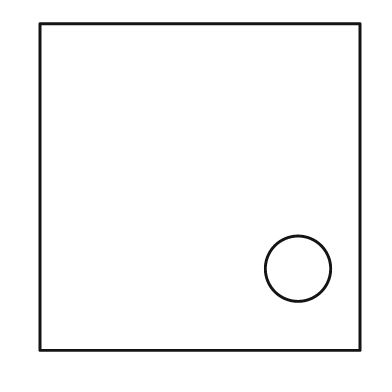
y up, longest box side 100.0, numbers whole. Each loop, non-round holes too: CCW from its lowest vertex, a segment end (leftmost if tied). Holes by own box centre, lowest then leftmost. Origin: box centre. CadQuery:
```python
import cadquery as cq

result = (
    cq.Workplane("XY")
    .moveTo(-49.0, -50.0)
    .lineTo(49.0, -50.0)
    .lineTo(49.0, 50.0)
    .lineTo(-49.0, 50.0)
    .close()
    .moveTo(30.0, -25.0)
    .circle(10.0)
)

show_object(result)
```